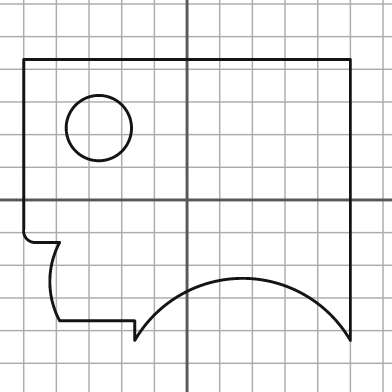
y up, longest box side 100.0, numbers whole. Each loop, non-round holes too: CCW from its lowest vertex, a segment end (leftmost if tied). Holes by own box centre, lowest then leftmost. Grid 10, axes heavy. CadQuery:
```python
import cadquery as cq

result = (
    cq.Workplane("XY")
    .moveTo(-16.0, -43.0)
    .threePointArc((17.0, -24.0), (50.0, -43.0))
    .lineTo(50.0, 43.0)
    .lineTo(-50.0, 43.0)
    .lineTo(-50.0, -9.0)
    .threePointArc((-49.0, -12.0), (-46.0, -13.0))
    .lineTo(-39.0, -13.0)
    .threePointArc((-42.0, -25.0), (-39.0, -37.0))
    .lineTo(-16.0, -37.0)
    .close()
    .moveTo(-27.0, 22.0)
    .circle(10.0)
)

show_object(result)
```